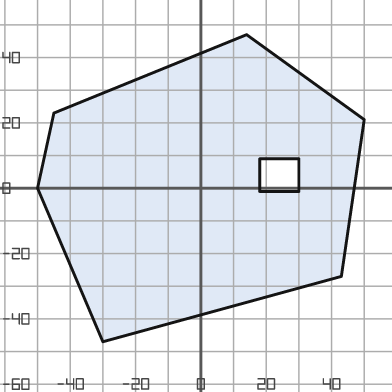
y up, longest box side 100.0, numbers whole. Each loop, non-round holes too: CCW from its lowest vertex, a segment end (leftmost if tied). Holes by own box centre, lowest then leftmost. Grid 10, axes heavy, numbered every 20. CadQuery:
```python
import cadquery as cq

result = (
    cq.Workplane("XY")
    .moveTo(-30.0, -47.0)
    .lineTo(43.0, -27.0)
    .lineTo(50.0, 21.0)
    .lineTo(14.0, 47.0)
    .lineTo(-45.0, 23.0)
    .lineTo(-50.0, 0.0)
    .close()
    .moveTo(18.0, -1.0)
    .lineTo(30.0, -1.0)
    .lineTo(30.0, 9.0)
    .lineTo(18.0, 9.0)
    .close()
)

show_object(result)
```